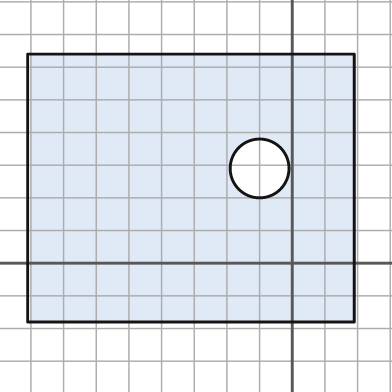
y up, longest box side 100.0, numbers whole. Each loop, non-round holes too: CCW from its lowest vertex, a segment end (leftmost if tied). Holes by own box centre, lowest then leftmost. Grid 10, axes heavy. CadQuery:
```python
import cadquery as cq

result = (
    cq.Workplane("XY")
    .moveTo(-81.0, -18.0)
    .lineTo(19.0, -18.0)
    .lineTo(19.0, 64.0)
    .lineTo(-81.0, 64.0)
    .close()
    .moveTo(-10.0, 29.0)
    .circle(9.0)
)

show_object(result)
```